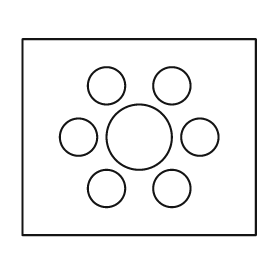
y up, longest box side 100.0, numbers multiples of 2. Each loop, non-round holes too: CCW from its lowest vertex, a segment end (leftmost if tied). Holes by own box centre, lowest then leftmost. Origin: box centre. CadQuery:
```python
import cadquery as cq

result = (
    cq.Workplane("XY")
    .moveTo(-50.0, -42.0)
    .lineTo(50.0, -42.0)
    .lineTo(50.0, 42.0)
    .lineTo(-50.0, 42.0)
    .close()
    .moveTo(-14.0, -22.0)
    .circle(8.0)
    .moveTo(14.0, -22.0)
    .circle(8.0)
    .moveTo(-26.0, 0.0)
    .circle(8.0)
    .moveTo(0.0, 0.0)
    .circle(14.0)
    .moveTo(26.0, 0.0)
    .circle(8.0)
    .moveTo(-14.0, 22.0)
    .circle(8.0)
    .moveTo(14.0, 22.0)
    .circle(8.0)
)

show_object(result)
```